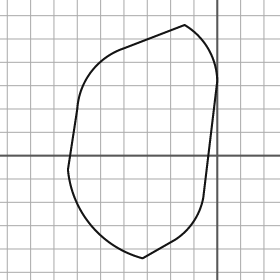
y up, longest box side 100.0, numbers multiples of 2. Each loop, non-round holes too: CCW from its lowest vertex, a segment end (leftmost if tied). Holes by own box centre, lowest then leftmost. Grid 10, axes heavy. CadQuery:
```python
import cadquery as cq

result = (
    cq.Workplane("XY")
    .moveTo(-32.0, -44.0)
    .lineTo(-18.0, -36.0)
    .threePointArc((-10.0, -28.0), (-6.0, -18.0))
    .lineTo(0.0, 32.0)
    .threePointArc((-4.0, 46.0), (-14.0, 56.0))
    .lineTo(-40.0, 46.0)
    .threePointArc((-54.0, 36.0), (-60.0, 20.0))
    .lineTo(-64.0, -6.0)
    .threePointArc((-54.0, -30.0), (-32.0, -44.0))
    .close()
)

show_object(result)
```